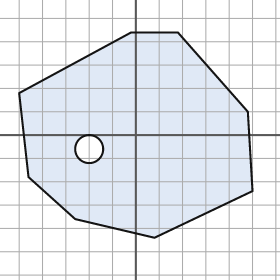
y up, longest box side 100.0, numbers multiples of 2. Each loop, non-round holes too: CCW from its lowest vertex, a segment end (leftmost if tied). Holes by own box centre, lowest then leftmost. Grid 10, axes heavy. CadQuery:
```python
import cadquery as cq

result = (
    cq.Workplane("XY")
    .moveTo(8.0, -44.0)
    .lineTo(50.0, -24.0)
    .lineTo(48.0, 10.0)
    .lineTo(18.0, 44.0)
    .lineTo(-2.0, 44.0)
    .lineTo(-50.0, 18.0)
    .lineTo(-46.0, -18.0)
    .lineTo(-26.0, -36.0)
    .close()
    .moveTo(-20.0, -6.0)
    .circle(6.0)
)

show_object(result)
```